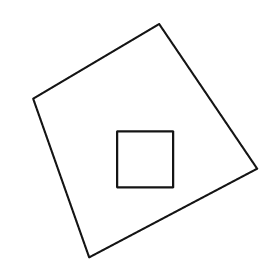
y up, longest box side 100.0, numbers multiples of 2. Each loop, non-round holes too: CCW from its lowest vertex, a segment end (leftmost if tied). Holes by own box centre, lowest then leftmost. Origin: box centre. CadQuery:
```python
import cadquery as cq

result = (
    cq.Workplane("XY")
    .moveTo(-24.0, -50.0)
    .lineTo(48.0, -12.0)
    .lineTo(6.0, 50.0)
    .lineTo(-48.0, 18.0)
    .close()
    .moveTo(-12.0, -20.0)
    .lineTo(12.0, -20.0)
    .lineTo(12.0, 4.0)
    .lineTo(-12.0, 4.0)
    .close()
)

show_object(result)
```